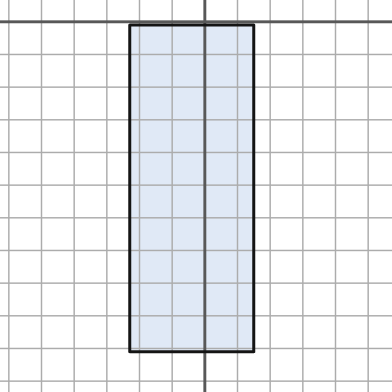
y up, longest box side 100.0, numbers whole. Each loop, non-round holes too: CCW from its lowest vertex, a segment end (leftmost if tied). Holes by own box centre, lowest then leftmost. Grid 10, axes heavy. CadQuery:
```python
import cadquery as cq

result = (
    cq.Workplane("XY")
    .moveTo(-23.0, -101.0)
    .lineTo(15.0, -101.0)
    .lineTo(15.0, -1.0)
    .lineTo(-23.0, -1.0)
    .close()
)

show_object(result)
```